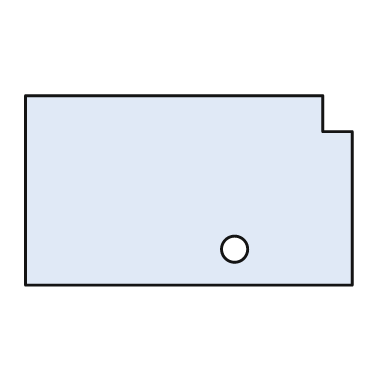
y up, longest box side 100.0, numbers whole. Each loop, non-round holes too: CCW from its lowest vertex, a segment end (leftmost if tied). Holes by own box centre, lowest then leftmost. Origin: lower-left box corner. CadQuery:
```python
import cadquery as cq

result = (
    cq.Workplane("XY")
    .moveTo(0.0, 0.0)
    .lineTo(100.0, 0.0)
    .lineTo(100.0, 47.0)
    .lineTo(91.0, 47.0)
    .lineTo(91.0, 58.0)
    .lineTo(0.0, 58.0)
    .close()
    .moveTo(64.0, 11.0)
    .circle(4.0)
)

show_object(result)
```